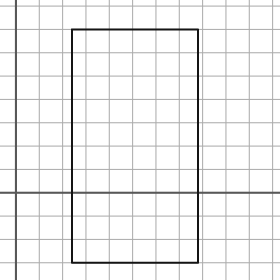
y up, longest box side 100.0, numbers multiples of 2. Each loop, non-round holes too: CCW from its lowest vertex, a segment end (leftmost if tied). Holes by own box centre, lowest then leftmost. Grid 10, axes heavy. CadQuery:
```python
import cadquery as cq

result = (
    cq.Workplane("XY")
    .moveTo(24.0, -30.0)
    .lineTo(78.0, -30.0)
    .lineTo(78.0, 70.0)
    .lineTo(24.0, 70.0)
    .close()
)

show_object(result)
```